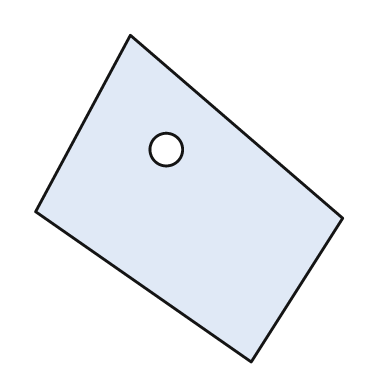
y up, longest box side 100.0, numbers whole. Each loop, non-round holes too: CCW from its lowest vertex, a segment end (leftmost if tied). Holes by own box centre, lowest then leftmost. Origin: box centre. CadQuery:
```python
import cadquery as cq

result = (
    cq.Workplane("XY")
    .moveTo(19.0, -50.0)
    .lineTo(47.0, -6.0)
    .lineTo(-18.0, 50.0)
    .lineTo(-47.0, -4.0)
    .close()
    .moveTo(-7.0, 15.0)
    .circle(5.0)
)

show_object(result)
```